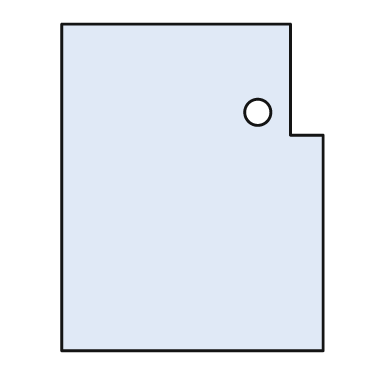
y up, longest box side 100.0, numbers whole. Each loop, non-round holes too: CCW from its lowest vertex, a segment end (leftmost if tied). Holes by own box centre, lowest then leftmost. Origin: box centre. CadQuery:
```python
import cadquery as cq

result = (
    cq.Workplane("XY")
    .moveTo(-40.0, -50.0)
    .lineTo(40.0, -50.0)
    .lineTo(40.0, 16.0)
    .lineTo(30.0, 16.0)
    .lineTo(30.0, 50.0)
    .lineTo(-40.0, 50.0)
    .close()
    .moveTo(20.0, 23.0)
    .circle(4.0)
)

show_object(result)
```